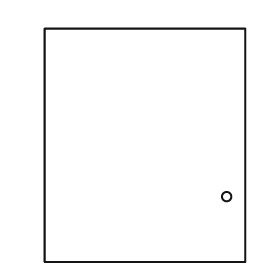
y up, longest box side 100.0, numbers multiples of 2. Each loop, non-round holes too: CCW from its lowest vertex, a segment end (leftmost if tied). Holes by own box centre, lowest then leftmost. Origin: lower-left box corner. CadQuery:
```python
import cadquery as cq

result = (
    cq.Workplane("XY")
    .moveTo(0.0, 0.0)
    .lineTo(86.0, 0.0)
    .lineTo(86.0, 100.0)
    .lineTo(0.0, 100.0)
    .close()
    .moveTo(78.0, 28.0)
    .circle(2.0)
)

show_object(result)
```